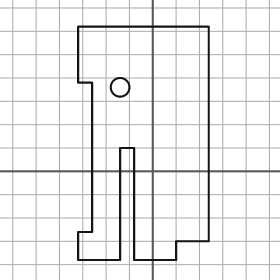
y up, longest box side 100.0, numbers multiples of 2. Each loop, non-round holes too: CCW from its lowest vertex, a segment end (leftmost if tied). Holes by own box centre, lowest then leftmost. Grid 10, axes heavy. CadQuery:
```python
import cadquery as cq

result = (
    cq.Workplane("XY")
    .moveTo(-32.0, -38.0)
    .lineTo(-14.0, -38.0)
    .lineTo(-14.0, 10.0)
    .lineTo(-8.0, 10.0)
    .lineTo(-8.0, -38.0)
    .lineTo(10.0, -38.0)
    .lineTo(10.0, -30.0)
    .lineTo(24.0, -30.0)
    .lineTo(24.0, 62.0)
    .lineTo(-32.0, 62.0)
    .lineTo(-32.0, 38.0)
    .lineTo(-26.0, 38.0)
    .lineTo(-26.0, -26.0)
    .lineTo(-32.0, -26.0)
    .close()
    .moveTo(-14.0, 36.0)
    .circle(4.0)
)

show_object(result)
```